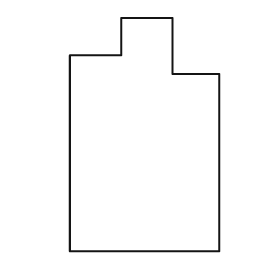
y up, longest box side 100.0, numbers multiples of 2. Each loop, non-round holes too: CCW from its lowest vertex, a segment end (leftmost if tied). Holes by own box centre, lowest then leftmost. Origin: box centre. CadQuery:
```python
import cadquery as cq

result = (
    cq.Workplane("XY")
    .moveTo(-32.0, -50.0)
    .lineTo(32.0, -50.0)
    .lineTo(32.0, 26.0)
    .lineTo(12.0, 26.0)
    .lineTo(12.0, 50.0)
    .lineTo(-10.0, 50.0)
    .lineTo(-10.0, 34.0)
    .lineTo(-32.0, 34.0)
    .close()
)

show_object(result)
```